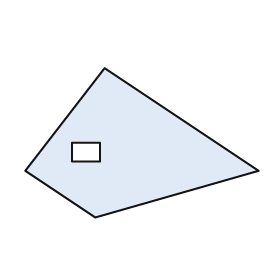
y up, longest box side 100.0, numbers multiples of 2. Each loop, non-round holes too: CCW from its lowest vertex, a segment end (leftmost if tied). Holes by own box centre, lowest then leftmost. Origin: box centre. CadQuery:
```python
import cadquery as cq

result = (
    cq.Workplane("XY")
    .moveTo(-20.0, -32.0)
    .lineTo(50.0, -12.0)
    .lineTo(-16.0, 32.0)
    .lineTo(-50.0, -12.0)
    .close()
    .moveTo(-30.0, -8.0)
    .lineTo(-18.0, -8.0)
    .lineTo(-18.0, 0.0)
    .lineTo(-30.0, 0.0)
    .close()
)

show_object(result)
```